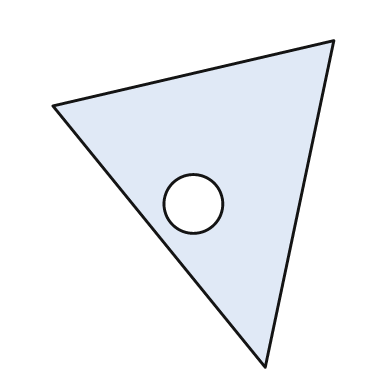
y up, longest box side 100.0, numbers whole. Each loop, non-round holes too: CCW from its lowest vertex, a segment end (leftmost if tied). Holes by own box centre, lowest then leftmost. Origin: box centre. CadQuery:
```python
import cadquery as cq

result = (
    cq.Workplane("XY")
    .moveTo(22.0, -50.0)
    .lineTo(43.0, 50.0)
    .lineTo(-43.0, 30.0)
    .close()
    .moveTo(0.0, 0.0)
    .circle(9.0)
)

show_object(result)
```